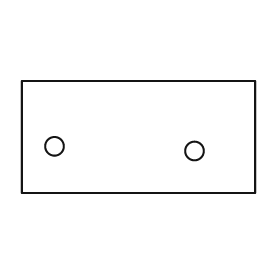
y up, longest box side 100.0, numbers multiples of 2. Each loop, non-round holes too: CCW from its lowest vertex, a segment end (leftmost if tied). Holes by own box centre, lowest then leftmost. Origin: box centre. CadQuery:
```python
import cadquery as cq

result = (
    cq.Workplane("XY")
    .moveTo(-50.0, -24.0)
    .lineTo(50.0, -24.0)
    .lineTo(50.0, 24.0)
    .lineTo(-50.0, 24.0)
    .close()
    .moveTo(24.0, -6.0)
    .circle(4.0)
    .moveTo(-36.0, -4.0)
    .circle(4.0)
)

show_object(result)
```